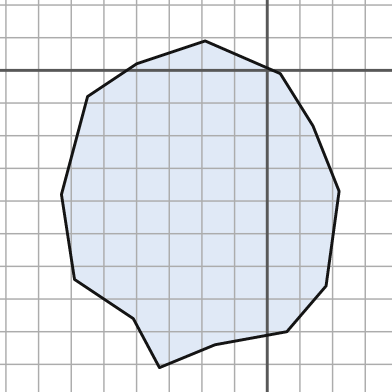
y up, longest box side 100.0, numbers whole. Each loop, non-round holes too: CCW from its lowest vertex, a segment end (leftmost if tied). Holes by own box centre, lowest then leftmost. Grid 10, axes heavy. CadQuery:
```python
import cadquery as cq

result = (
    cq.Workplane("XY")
    .moveTo(-33.0, -91.0)
    .lineTo(-16.0, -84.0)
    .lineTo(6.0, -80.0)
    .lineTo(18.0, -66.0)
    .lineTo(22.0, -37.0)
    .lineTo(14.0, -17.0)
    .lineTo(4.0, -1.0)
    .lineTo(-19.0, 9.0)
    .lineTo(-40.0, 2.0)
    .lineTo(-55.0, -8.0)
    .lineTo(-63.0, -38.0)
    .lineTo(-59.0, -64.0)
    .lineTo(-41.0, -76.0)
    .close()
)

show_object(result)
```